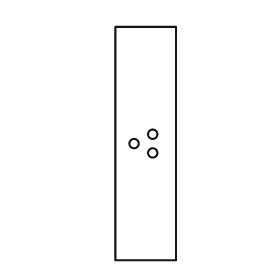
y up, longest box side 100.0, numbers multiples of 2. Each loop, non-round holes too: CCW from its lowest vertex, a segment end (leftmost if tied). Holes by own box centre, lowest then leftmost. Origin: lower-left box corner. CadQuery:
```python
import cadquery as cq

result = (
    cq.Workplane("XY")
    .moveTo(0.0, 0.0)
    .lineTo(26.0, 0.0)
    .lineTo(26.0, 100.0)
    .lineTo(0.0, 100.0)
    .close()
    .moveTo(16.0, 46.0)
    .circle(2.0)
    .moveTo(8.0, 50.0)
    .circle(2.0)
    .moveTo(16.0, 54.0)
    .circle(2.0)
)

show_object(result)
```